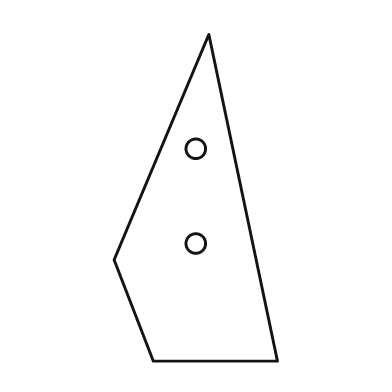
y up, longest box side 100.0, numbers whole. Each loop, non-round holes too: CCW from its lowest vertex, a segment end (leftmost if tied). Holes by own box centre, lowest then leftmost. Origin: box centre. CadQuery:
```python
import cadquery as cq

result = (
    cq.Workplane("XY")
    .moveTo(-13.0, -50.0)
    .lineTo(25.0, -50.0)
    .lineTo(4.0, 50.0)
    .lineTo(-25.0, -19.0)
    .close()
    .moveTo(0.0, -14.0)
    .circle(3.0)
    .moveTo(0.0, 15.0)
    .circle(3.0)
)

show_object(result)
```